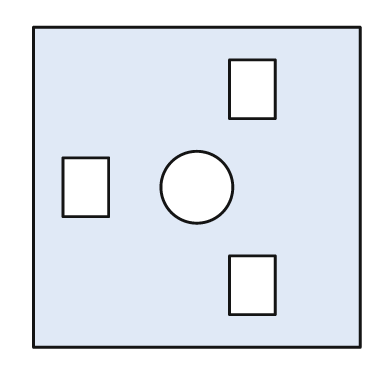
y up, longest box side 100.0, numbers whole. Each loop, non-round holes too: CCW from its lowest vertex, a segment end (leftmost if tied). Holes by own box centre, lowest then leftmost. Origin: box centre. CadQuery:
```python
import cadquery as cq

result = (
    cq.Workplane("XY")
    .moveTo(-50.0, -49.0)
    .lineTo(50.0, -49.0)
    .lineTo(50.0, 49.0)
    .lineTo(-50.0, 49.0)
    .close()
    .moveTo(10.0, -39.0)
    .lineTo(24.0, -39.0)
    .lineTo(24.0, -21.0)
    .lineTo(10.0, -21.0)
    .close()
    .moveTo(-41.0, -9.0)
    .lineTo(-27.0, -9.0)
    .lineTo(-27.0, 9.0)
    .lineTo(-41.0, 9.0)
    .close()
    .moveTo(0.0, 0.0)
    .circle(11.0)
    .moveTo(10.0, 21.0)
    .lineTo(24.0, 21.0)
    .lineTo(24.0, 39.0)
    .lineTo(10.0, 39.0)
    .close()
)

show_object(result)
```